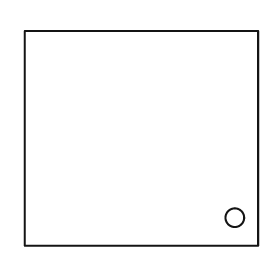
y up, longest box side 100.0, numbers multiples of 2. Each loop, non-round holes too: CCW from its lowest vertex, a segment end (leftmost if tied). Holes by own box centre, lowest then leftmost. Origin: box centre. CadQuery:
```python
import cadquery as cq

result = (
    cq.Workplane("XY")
    .moveTo(-50.0, -46.0)
    .lineTo(50.0, -46.0)
    .lineTo(50.0, 46.0)
    .lineTo(-50.0, 46.0)
    .close()
    .moveTo(40.0, -34.0)
    .circle(4.0)
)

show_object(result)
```